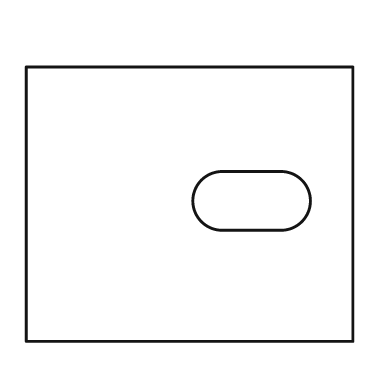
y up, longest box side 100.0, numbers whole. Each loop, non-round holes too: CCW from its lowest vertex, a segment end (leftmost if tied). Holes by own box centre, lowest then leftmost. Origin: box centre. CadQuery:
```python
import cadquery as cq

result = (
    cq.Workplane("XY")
    .moveTo(-50.0, -42.0)
    .lineTo(50.0, -42.0)
    .lineTo(50.0, 42.0)
    .lineTo(-50.0, 42.0)
    .close()
    .moveTo(10.0, -8.0)
    .lineTo(28.0, -8.0)
    .threePointArc((37.0, 1.0), (28.0, 10.0))
    .lineTo(10.0, 10.0)
    .threePointArc((1.0, 1.0), (10.0, -8.0))
    .close()
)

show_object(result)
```